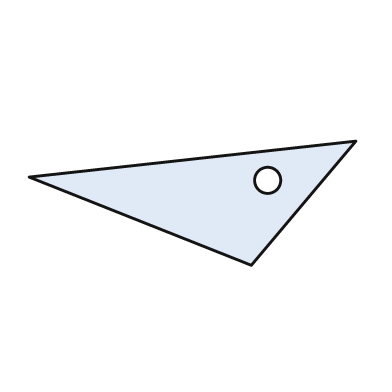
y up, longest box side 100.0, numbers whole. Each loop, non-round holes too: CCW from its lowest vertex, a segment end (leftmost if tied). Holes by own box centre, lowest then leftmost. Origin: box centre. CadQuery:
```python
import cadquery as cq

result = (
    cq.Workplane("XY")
    .moveTo(18.0, -19.0)
    .lineTo(50.0, 19.0)
    .lineTo(-50.0, 8.0)
    .close()
    .moveTo(23.0, 7.0)
    .circle(4.0)
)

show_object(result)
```